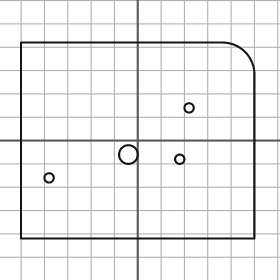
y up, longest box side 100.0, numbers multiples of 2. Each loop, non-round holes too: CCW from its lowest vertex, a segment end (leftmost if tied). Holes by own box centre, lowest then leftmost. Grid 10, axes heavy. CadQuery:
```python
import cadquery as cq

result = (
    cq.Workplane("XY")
    .moveTo(-50.0, -42.0)
    .lineTo(50.0, -42.0)
    .lineTo(50.0, 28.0)
    .threePointArc((46.0, 38.0), (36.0, 42.0))
    .lineTo(-50.0, 42.0)
    .close()
    .moveTo(-38.0, -16.0)
    .circle(2.0)
    .moveTo(18.0, -8.0)
    .circle(2.0)
    .moveTo(-4.0, -6.0)
    .circle(4.0)
    .moveTo(22.0, 14.0)
    .circle(2.0)
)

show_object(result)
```